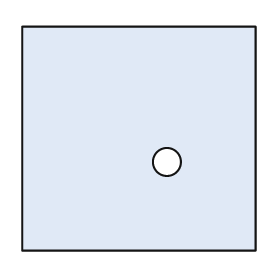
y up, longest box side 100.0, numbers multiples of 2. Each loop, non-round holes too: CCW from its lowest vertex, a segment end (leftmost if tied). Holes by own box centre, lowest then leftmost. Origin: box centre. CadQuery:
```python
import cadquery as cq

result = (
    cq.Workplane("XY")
    .moveTo(-50.0, -48.0)
    .lineTo(50.0, -48.0)
    .lineTo(50.0, 48.0)
    .lineTo(-50.0, 48.0)
    .close()
    .moveTo(12.0, -10.0)
    .circle(6.0)
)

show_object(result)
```